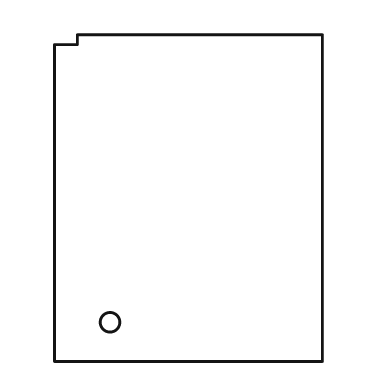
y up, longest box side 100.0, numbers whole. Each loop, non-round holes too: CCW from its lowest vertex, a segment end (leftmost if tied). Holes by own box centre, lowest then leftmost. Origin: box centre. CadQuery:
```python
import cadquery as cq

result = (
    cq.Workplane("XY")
    .moveTo(-41.0, -50.0)
    .lineTo(41.0, -50.0)
    .lineTo(41.0, 50.0)
    .lineTo(-34.0, 50.0)
    .lineTo(-34.0, 47.0)
    .lineTo(-41.0, 47.0)
    .close()
    .moveTo(-24.0, -38.0)
    .circle(3.0)
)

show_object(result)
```